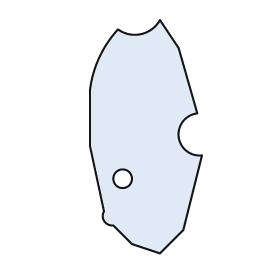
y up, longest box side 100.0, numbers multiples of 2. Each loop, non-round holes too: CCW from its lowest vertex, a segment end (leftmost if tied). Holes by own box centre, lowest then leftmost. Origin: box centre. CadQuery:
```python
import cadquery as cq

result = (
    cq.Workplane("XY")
    .moveTo(6.0, -50.0)
    .lineTo(16.0, -40.0)
    .lineTo(24.0, -8.0)
    .threePointArc((14.0, 0.0), (22.0, 10.0))
    .lineTo(14.0, 38.0)
    .lineTo(6.0, 50.0)
    .threePointArc((-2.0, 44.0), (-12.0, 46.0))
    .threePointArc((-20.0, 34.0), (-24.0, 20.0))
    .lineTo(-24.0, -4.0)
    .lineTo(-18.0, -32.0)
    .threePointArc((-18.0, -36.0), (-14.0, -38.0))
    .lineTo(-6.0, -46.0)
    .close()
    .moveTo(-10.0, -18.0)
    .circle(4.0)
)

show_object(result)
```